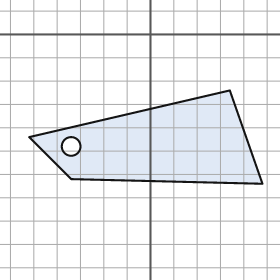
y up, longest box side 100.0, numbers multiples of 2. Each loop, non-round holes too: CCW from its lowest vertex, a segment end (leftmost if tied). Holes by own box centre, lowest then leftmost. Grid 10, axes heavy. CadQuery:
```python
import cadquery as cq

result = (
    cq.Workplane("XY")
    .moveTo(48.0, -64.0)
    .lineTo(34.0, -24.0)
    .lineTo(-52.0, -44.0)
    .lineTo(-34.0, -62.0)
    .close()
    .moveTo(-34.0, -48.0)
    .circle(4.0)
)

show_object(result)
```